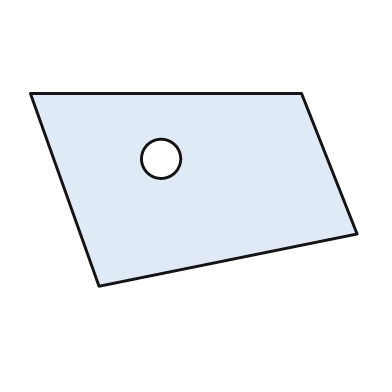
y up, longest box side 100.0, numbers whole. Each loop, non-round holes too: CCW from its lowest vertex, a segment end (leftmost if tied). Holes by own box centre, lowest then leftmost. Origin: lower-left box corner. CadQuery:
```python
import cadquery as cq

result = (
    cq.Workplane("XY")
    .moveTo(21.0, 0.0)
    .lineTo(100.0, 16.0)
    .lineTo(83.0, 59.0)
    .lineTo(0.0, 59.0)
    .close()
    .moveTo(40.0, 39.0)
    .circle(6.0)
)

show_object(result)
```